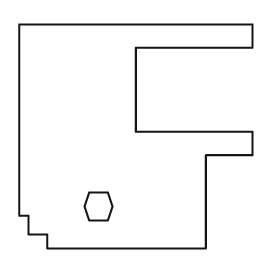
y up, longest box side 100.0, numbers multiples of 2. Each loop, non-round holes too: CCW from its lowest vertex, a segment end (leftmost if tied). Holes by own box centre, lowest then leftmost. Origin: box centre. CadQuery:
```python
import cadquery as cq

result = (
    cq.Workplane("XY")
    .moveTo(-38.0, -48.0)
    .lineTo(30.0, -48.0)
    .lineTo(30.0, -8.0)
    .lineTo(50.0, -8.0)
    .lineTo(50.0, 2.0)
    .lineTo(0.0, 2.0)
    .lineTo(0.0, 38.0)
    .lineTo(50.0, 38.0)
    .lineTo(50.0, 48.0)
    .lineTo(-50.0, 48.0)
    .lineTo(-50.0, -34.0)
    .lineTo(-46.0, -34.0)
    .lineTo(-46.0, -42.0)
    .lineTo(-38.0, -42.0)
    .close()
    .moveTo(-20.0, -36.0)
    .lineTo(-12.0, -36.0)
    .lineTo(-10.0, -30.0)
    .lineTo(-12.0, -24.0)
    .lineTo(-20.0, -24.0)
    .lineTo(-22.0, -30.0)
    .close()
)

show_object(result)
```